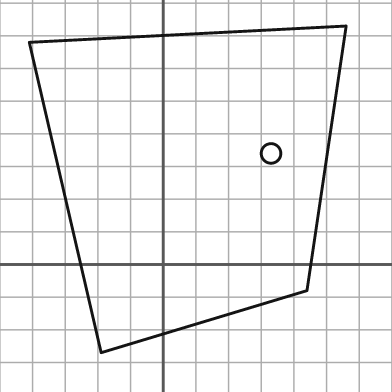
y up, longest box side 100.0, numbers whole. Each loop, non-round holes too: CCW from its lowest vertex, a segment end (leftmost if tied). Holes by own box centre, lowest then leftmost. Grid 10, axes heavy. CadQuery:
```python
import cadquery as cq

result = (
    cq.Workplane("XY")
    .moveTo(-19.0, -27.0)
    .lineTo(44.0, -8.0)
    .lineTo(56.0, 73.0)
    .lineTo(-41.0, 68.0)
    .close()
    .moveTo(33.0, 34.0)
    .circle(3.0)
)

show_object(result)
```